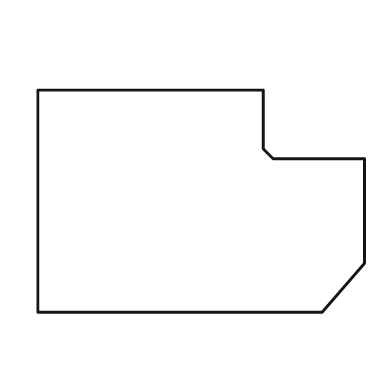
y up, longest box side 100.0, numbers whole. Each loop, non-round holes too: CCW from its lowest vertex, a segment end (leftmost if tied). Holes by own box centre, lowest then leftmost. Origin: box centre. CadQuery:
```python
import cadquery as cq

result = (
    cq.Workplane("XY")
    .moveTo(-50.0, -34.0)
    .lineTo(37.0, -34.0)
    .lineTo(50.0, -19.0)
    .lineTo(50.0, 13.0)
    .lineTo(22.0, 13.0)
    .lineTo(19.0, 16.0)
    .lineTo(19.0, 34.0)
    .lineTo(-50.0, 34.0)
    .close()
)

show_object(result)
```